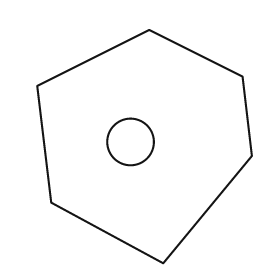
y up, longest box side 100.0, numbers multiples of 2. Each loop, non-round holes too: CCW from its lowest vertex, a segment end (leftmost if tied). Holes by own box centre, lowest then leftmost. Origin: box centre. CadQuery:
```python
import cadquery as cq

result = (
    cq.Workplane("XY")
    .moveTo(8.0, -50.0)
    .lineTo(46.0, -4.0)
    .lineTo(42.0, 30.0)
    .lineTo(2.0, 50.0)
    .lineTo(-46.0, 26.0)
    .lineTo(-40.0, -24.0)
    .close()
    .moveTo(-6.0, 2.0)
    .circle(10.0)
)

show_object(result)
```